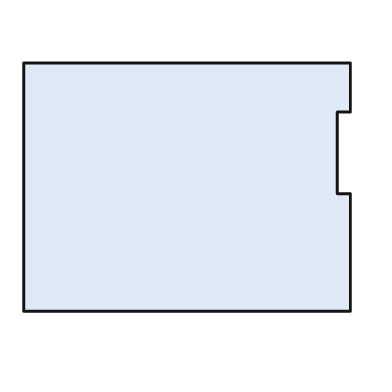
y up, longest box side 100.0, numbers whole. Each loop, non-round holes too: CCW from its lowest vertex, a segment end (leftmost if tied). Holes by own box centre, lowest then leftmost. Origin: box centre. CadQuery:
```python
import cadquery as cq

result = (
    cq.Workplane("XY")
    .moveTo(-50.0, -38.0)
    .lineTo(50.0, -38.0)
    .lineTo(50.0, -2.0)
    .lineTo(46.0, -2.0)
    .lineTo(46.0, 23.0)
    .lineTo(50.0, 23.0)
    .lineTo(50.0, 38.0)
    .lineTo(-50.0, 38.0)
    .close()
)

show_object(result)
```